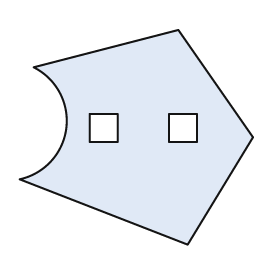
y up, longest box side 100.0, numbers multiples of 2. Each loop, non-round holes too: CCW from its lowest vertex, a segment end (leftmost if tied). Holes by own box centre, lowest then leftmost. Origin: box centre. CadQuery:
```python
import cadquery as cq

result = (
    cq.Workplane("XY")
    .moveTo(22.0, -46.0)
    .lineTo(50.0, 0.0)
    .lineTo(18.0, 46.0)
    .lineTo(-44.0, 30.0)
    .threePointArc((-30.0, 4.0), (-50.0, -18.0))
    .close()
    .moveTo(-20.0, -2.0)
    .lineTo(-8.0, -2.0)
    .lineTo(-8.0, 10.0)
    .lineTo(-20.0, 10.0)
    .close()
    .moveTo(14.0, -2.0)
    .lineTo(26.0, -2.0)
    .lineTo(26.0, 10.0)
    .lineTo(14.0, 10.0)
    .close()
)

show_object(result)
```